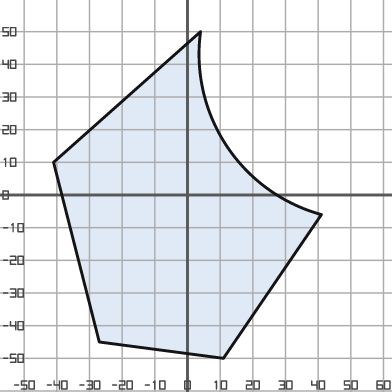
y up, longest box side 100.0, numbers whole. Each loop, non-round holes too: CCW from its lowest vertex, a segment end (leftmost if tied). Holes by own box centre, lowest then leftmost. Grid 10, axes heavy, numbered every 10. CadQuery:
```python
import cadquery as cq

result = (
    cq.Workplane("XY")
    .moveTo(11.0, -50.0)
    .lineTo(41.0, -6.0)
    .threePointArc((12.0, 15.0), (4.0, 50.0))
    .lineTo(-41.0, 10.0)
    .lineTo(-27.0, -45.0)
    .close()
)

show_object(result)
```